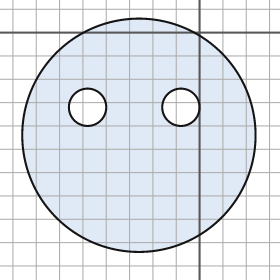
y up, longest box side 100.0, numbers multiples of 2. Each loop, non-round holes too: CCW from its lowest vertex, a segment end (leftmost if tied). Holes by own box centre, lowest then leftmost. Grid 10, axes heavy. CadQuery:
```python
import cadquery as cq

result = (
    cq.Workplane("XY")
    .moveTo(-26.0, -44.0)
    .circle(50.0)
    .moveTo(-48.0, -32.0)
    .circle(8.0)
    .moveTo(-8.0, -32.0)
    .circle(8.0)
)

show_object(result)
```